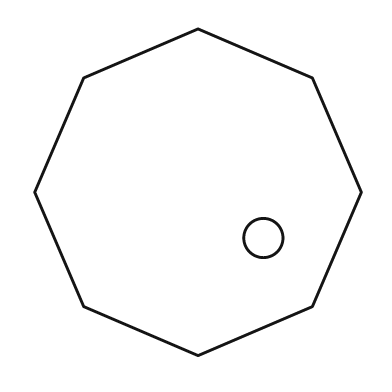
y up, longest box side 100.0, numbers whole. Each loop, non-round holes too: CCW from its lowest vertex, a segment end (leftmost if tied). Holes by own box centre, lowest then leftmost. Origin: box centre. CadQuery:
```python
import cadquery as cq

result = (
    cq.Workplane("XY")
    .moveTo(0.0, -50.0)
    .lineTo(35.0, -35.0)
    .lineTo(50.0, 0.0)
    .lineTo(35.0, 35.0)
    .lineTo(0.0, 50.0)
    .lineTo(-35.0, 35.0)
    .lineTo(-50.0, 0.0)
    .lineTo(-35.0, -35.0)
    .close()
    .moveTo(20.0, -14.0)
    .circle(6.0)
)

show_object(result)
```